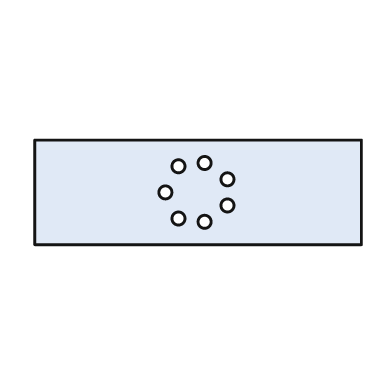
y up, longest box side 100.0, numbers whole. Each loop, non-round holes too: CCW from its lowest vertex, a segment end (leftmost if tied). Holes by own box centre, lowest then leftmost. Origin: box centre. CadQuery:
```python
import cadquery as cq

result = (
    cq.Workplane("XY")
    .moveTo(-50.0, -16.0)
    .lineTo(50.0, -16.0)
    .lineTo(50.0, 16.0)
    .lineTo(-50.0, 16.0)
    .close()
    .moveTo(2.0, -9.0)
    .circle(2.0)
    .moveTo(-6.0, -8.0)
    .circle(2.0)
    .moveTo(9.0, -4.0)
    .circle(2.0)
    .moveTo(-10.0, 0.0)
    .circle(2.0)
    .moveTo(9.0, 4.0)
    .circle(2.0)
    .moveTo(-6.0, 8.0)
    .circle(2.0)
    .moveTo(2.0, 9.0)
    .circle(2.0)
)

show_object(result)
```